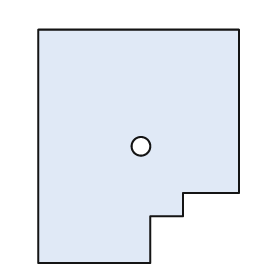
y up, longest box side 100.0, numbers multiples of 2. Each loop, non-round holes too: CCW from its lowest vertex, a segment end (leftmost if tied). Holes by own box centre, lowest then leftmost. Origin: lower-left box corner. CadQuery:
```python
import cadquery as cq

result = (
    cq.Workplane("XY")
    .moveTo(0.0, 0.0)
    .lineTo(48.0, 0.0)
    .lineTo(48.0, 20.0)
    .lineTo(62.0, 20.0)
    .lineTo(62.0, 30.0)
    .lineTo(86.0, 30.0)
    .lineTo(86.0, 100.0)
    .lineTo(0.0, 100.0)
    .close()
    .moveTo(44.0, 50.0)
    .circle(4.0)
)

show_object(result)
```